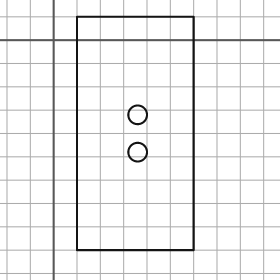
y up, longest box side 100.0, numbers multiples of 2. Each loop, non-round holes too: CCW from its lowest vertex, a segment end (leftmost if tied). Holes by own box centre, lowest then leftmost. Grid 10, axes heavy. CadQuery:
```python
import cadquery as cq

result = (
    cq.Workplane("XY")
    .moveTo(10.0, -90.0)
    .lineTo(60.0, -90.0)
    .lineTo(60.0, 10.0)
    .lineTo(10.0, 10.0)
    .close()
    .moveTo(36.0, -48.0)
    .circle(4.0)
    .moveTo(36.0, -32.0)
    .circle(4.0)
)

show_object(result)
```